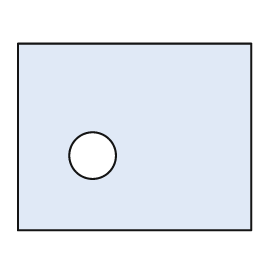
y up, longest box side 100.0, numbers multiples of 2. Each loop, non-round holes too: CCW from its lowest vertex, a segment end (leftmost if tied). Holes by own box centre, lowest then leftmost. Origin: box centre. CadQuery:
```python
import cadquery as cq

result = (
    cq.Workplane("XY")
    .moveTo(-50.0, -40.0)
    .lineTo(50.0, -40.0)
    .lineTo(50.0, 40.0)
    .lineTo(-50.0, 40.0)
    .close()
    .moveTo(-18.0, -8.0)
    .circle(10.0)
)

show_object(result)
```